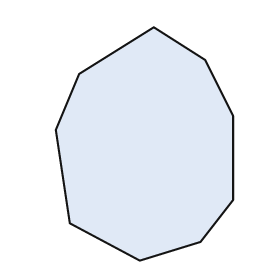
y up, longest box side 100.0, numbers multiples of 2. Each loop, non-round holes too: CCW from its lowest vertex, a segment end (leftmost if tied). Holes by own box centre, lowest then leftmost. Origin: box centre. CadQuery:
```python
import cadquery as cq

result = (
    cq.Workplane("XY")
    .moveTo(-2.0, -50.0)
    .lineTo(24.0, -42.0)
    .lineTo(38.0, -24.0)
    .lineTo(38.0, 12.0)
    .lineTo(26.0, 36.0)
    .lineTo(4.0, 50.0)
    .lineTo(-28.0, 30.0)
    .lineTo(-38.0, 6.0)
    .lineTo(-32.0, -34.0)
    .close()
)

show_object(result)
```